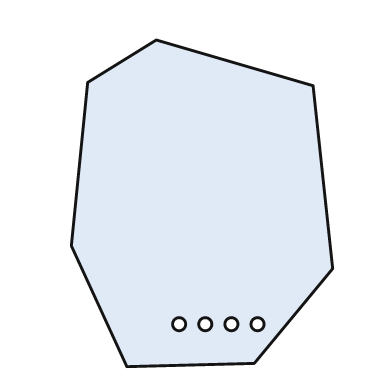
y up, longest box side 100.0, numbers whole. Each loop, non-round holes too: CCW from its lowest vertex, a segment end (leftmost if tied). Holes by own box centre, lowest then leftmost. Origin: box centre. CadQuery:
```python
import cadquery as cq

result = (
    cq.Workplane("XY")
    .moveTo(-23.0, -50.0)
    .lineTo(16.0, -49.0)
    .lineTo(40.0, -20.0)
    .lineTo(34.0, 36.0)
    .lineTo(-14.0, 50.0)
    .lineTo(-35.0, 37.0)
    .lineTo(-40.0, -13.0)
    .close()
    .moveTo(-7.0, -37.0)
    .circle(2.0)
    .moveTo(1.0, -37.0)
    .circle(2.0)
    .moveTo(9.0, -37.0)
    .circle(2.0)
    .moveTo(17.0, -37.0)
    .circle(2.0)
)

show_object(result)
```